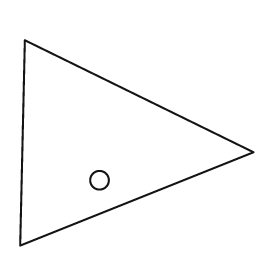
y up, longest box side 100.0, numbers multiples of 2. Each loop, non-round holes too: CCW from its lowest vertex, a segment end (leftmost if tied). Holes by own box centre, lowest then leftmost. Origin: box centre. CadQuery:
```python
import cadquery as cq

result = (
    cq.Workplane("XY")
    .moveTo(-50.0, -44.0)
    .lineTo(50.0, -4.0)
    .lineTo(-48.0, 44.0)
    .close()
    .moveTo(-16.0, -16.0)
    .circle(4.0)
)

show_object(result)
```